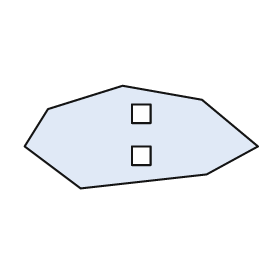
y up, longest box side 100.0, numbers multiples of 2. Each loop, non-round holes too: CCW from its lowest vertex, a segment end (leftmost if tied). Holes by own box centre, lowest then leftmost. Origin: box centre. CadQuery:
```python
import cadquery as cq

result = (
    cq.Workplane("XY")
    .moveTo(-26.0, -22.0)
    .lineTo(28.0, -16.0)
    .lineTo(50.0, -4.0)
    .lineTo(26.0, 16.0)
    .lineTo(-8.0, 22.0)
    .lineTo(-40.0, 12.0)
    .lineTo(-50.0, -4.0)
    .close()
    .moveTo(-4.0, -12.0)
    .lineTo(4.0, -12.0)
    .lineTo(4.0, -4.0)
    .lineTo(-4.0, -4.0)
    .close()
    .moveTo(-4.0, 6.0)
    .lineTo(4.0, 6.0)
    .lineTo(4.0, 14.0)
    .lineTo(-4.0, 14.0)
    .close()
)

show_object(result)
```